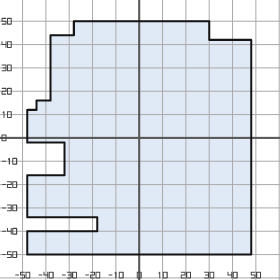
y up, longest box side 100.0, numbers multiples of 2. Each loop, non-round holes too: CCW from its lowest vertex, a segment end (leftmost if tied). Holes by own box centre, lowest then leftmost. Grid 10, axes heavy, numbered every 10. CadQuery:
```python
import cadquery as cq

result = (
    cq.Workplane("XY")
    .moveTo(-48.0, -50.0)
    .lineTo(48.0, -50.0)
    .lineTo(48.0, 42.0)
    .lineTo(30.0, 42.0)
    .lineTo(30.0, 50.0)
    .lineTo(-28.0, 50.0)
    .lineTo(-28.0, 44.0)
    .lineTo(-38.0, 44.0)
    .lineTo(-38.0, 16.0)
    .lineTo(-44.0, 16.0)
    .lineTo(-44.0, 12.0)
    .lineTo(-48.0, 12.0)
    .lineTo(-48.0, -2.0)
    .lineTo(-32.0, -2.0)
    .lineTo(-32.0, -16.0)
    .lineTo(-48.0, -16.0)
    .lineTo(-48.0, -34.0)
    .lineTo(-18.0, -34.0)
    .lineTo(-18.0, -40.0)
    .lineTo(-48.0, -40.0)
    .close()
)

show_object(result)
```